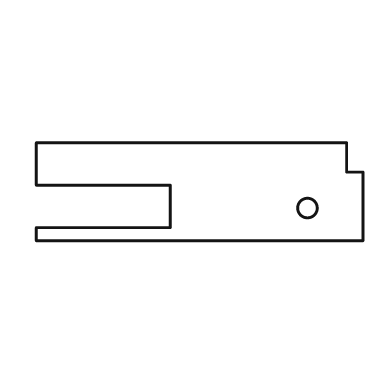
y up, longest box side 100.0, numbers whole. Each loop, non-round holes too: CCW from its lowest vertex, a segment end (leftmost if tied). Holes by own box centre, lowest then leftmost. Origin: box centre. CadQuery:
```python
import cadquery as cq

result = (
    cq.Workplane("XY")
    .moveTo(-50.0, -15.0)
    .lineTo(50.0, -15.0)
    .lineTo(50.0, 6.0)
    .lineTo(45.0, 6.0)
    .lineTo(45.0, 15.0)
    .lineTo(-50.0, 15.0)
    .lineTo(-50.0, 2.0)
    .lineTo(-9.0, 2.0)
    .lineTo(-9.0, -11.0)
    .lineTo(-50.0, -11.0)
    .close()
    .moveTo(33.0, -5.0)
    .circle(3.0)
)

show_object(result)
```